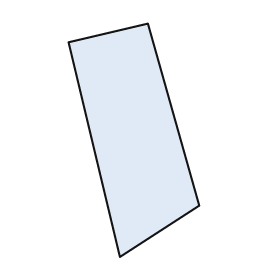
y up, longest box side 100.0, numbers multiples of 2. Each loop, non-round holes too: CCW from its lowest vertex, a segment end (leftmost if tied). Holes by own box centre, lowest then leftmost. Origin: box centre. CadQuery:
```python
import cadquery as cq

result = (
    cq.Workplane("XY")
    .moveTo(-6.0, -50.0)
    .lineTo(28.0, -28.0)
    .lineTo(6.0, 50.0)
    .lineTo(-28.0, 42.0)
    .close()
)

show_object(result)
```